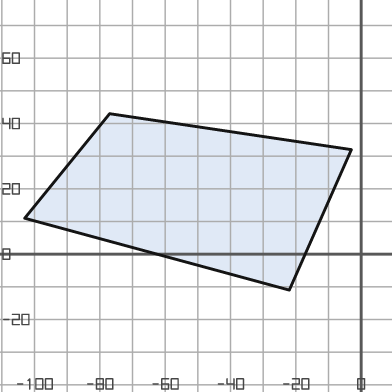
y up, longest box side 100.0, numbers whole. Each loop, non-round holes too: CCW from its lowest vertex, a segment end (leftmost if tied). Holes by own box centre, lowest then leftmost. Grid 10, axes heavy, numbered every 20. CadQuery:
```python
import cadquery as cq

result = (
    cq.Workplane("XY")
    .moveTo(-22.0, -11.0)
    .lineTo(-3.0, 32.0)
    .lineTo(-77.0, 43.0)
    .lineTo(-103.0, 11.0)
    .close()
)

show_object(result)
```